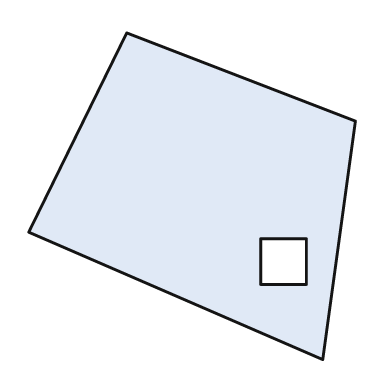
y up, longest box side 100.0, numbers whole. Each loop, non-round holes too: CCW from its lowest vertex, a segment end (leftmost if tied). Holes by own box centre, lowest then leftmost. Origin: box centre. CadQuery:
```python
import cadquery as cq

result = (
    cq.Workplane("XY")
    .moveTo(40.0, -50.0)
    .lineTo(50.0, 23.0)
    .lineTo(-20.0, 50.0)
    .lineTo(-50.0, -11.0)
    .close()
    .moveTo(21.0, -27.0)
    .lineTo(35.0, -27.0)
    .lineTo(35.0, -13.0)
    .lineTo(21.0, -13.0)
    .close()
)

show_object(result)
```